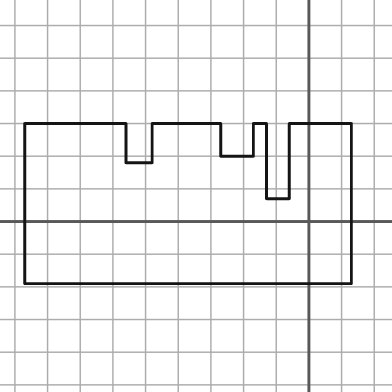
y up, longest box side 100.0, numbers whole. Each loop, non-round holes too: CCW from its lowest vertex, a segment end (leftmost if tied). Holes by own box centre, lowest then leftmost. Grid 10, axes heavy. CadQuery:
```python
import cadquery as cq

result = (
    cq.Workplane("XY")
    .moveTo(-87.0, -19.0)
    .lineTo(13.0, -19.0)
    .lineTo(13.0, 30.0)
    .lineTo(-6.0, 30.0)
    .lineTo(-6.0, 7.0)
    .lineTo(-13.0, 7.0)
    .lineTo(-13.0, 30.0)
    .lineTo(-17.0, 30.0)
    .lineTo(-17.0, 20.0)
    .lineTo(-27.0, 20.0)
    .lineTo(-27.0, 30.0)
    .lineTo(-48.0, 30.0)
    .lineTo(-48.0, 18.0)
    .lineTo(-56.0, 18.0)
    .lineTo(-56.0, 30.0)
    .lineTo(-87.0, 30.0)
    .close()
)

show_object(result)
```